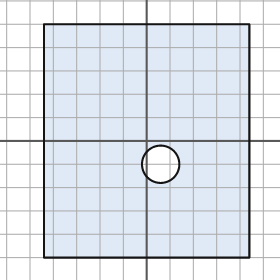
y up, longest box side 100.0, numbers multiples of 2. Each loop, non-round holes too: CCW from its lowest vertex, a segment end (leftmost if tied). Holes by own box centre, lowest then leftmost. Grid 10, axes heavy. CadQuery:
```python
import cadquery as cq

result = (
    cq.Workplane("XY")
    .moveTo(-44.0, -50.0)
    .lineTo(44.0, -50.0)
    .lineTo(44.0, 50.0)
    .lineTo(-44.0, 50.0)
    .close()
    .moveTo(6.0, -10.0)
    .circle(8.0)
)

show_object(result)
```